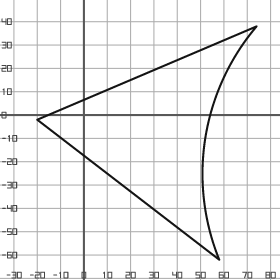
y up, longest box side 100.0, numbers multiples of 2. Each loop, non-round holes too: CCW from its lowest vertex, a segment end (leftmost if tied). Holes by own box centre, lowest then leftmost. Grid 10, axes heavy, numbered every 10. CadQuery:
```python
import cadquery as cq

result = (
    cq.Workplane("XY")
    .moveTo(58.0, -62.0)
    .threePointArc((52.0, -10.0), (74.0, 38.0))
    .lineTo(-20.0, -2.0)
    .close()
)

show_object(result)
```